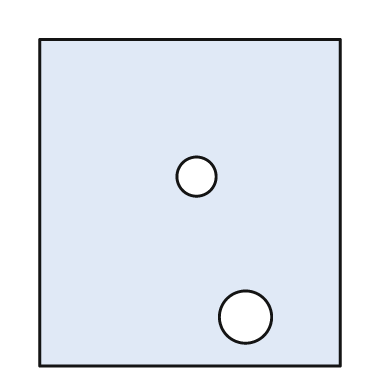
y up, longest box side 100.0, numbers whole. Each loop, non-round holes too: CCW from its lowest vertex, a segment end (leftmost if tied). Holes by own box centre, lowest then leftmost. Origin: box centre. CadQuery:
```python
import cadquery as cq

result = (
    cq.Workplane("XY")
    .moveTo(-46.0, -50.0)
    .lineTo(46.0, -50.0)
    .lineTo(46.0, 50.0)
    .lineTo(-46.0, 50.0)
    .close()
    .moveTo(17.0, -35.0)
    .circle(8.0)
    .moveTo(2.0, 8.0)
    .circle(6.0)
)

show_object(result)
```